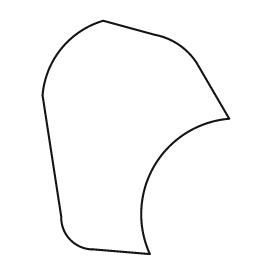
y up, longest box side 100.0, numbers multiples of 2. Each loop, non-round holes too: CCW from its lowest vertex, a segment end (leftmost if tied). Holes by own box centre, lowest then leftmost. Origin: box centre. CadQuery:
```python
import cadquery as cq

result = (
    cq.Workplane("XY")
    .moveTo(6.0, -50.0)
    .threePointArc((8.0, -12.0), (40.0, 8.0))
    .lineTo(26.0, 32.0)
    .threePointArc((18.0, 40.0), (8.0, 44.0))
    .lineTo(-14.0, 50.0)
    .threePointArc((-32.0, 38.0), (-40.0, 18.0))
    .lineTo(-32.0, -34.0)
    .threePointArc((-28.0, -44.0), (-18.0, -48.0))
    .close()
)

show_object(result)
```